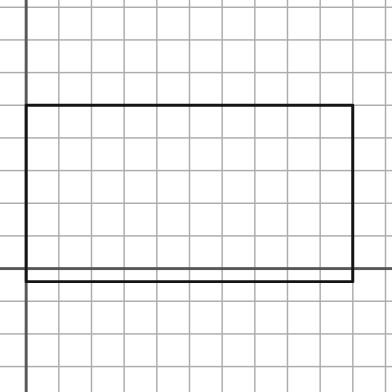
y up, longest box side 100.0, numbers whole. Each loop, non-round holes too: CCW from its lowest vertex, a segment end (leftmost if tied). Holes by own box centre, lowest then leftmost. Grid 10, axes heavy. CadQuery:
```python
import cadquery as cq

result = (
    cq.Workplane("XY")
    .moveTo(0.0, -4.0)
    .lineTo(100.0, -4.0)
    .lineTo(100.0, 50.0)
    .lineTo(0.0, 50.0)
    .close()
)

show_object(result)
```